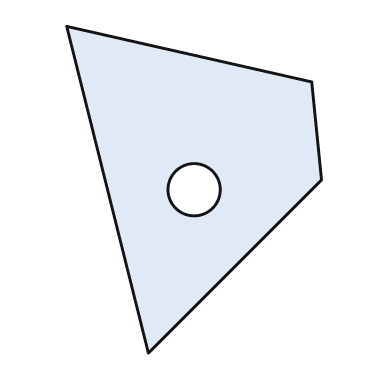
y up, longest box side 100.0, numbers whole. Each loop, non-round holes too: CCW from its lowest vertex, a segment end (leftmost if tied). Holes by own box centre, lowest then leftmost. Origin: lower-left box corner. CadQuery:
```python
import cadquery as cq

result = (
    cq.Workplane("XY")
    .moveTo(25.0, 0.0)
    .lineTo(78.0, 53.0)
    .lineTo(75.0, 83.0)
    .lineTo(0.0, 100.0)
    .close()
    .moveTo(39.0, 50.0)
    .circle(8.0)
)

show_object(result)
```